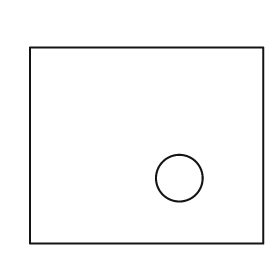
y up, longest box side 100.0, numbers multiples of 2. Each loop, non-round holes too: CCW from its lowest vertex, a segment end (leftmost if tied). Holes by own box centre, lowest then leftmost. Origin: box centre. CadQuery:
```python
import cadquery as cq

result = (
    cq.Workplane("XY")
    .moveTo(-50.0, -42.0)
    .lineTo(50.0, -42.0)
    .lineTo(50.0, 42.0)
    .lineTo(-50.0, 42.0)
    .close()
    .moveTo(14.0, -14.0)
    .circle(10.0)
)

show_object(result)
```